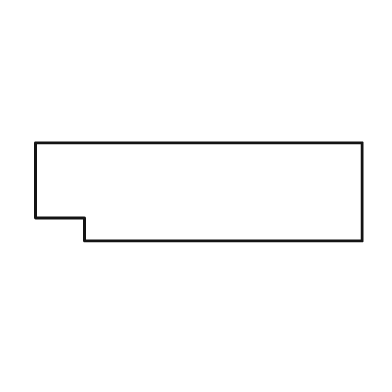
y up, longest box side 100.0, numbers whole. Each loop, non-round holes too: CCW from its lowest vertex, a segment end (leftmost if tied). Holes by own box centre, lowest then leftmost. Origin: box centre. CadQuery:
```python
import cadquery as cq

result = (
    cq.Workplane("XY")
    .moveTo(-35.0, -15.0)
    .lineTo(50.0, -15.0)
    .lineTo(50.0, 15.0)
    .lineTo(-50.0, 15.0)
    .lineTo(-50.0, -8.0)
    .lineTo(-35.0, -8.0)
    .close()
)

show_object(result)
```